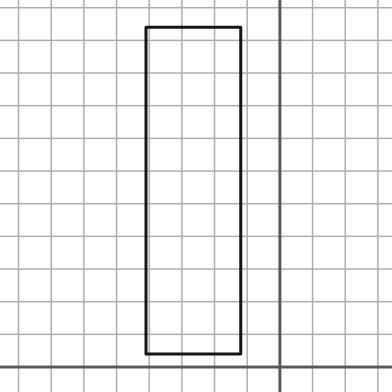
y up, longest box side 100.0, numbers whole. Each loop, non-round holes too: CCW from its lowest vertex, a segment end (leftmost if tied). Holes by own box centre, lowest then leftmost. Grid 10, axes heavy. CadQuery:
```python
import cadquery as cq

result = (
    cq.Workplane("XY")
    .moveTo(-41.0, 4.0)
    .lineTo(-12.0, 4.0)
    .lineTo(-12.0, 104.0)
    .lineTo(-41.0, 104.0)
    .close()
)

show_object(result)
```